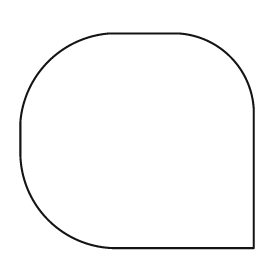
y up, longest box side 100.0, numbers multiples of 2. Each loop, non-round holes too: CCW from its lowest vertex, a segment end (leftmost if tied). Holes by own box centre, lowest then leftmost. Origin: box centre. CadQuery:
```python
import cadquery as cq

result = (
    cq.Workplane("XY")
    .moveTo(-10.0, -46.0)
    .lineTo(50.0, -46.0)
    .lineTo(50.0, 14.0)
    .threePointArc((40.0, 36.0), (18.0, 46.0))
    .lineTo(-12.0, 46.0)
    .threePointArc((-38.0, 34.0), (-50.0, 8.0))
    .lineTo(-50.0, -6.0)
    .threePointArc((-38.0, -34.0), (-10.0, -46.0))
    .close()
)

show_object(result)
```